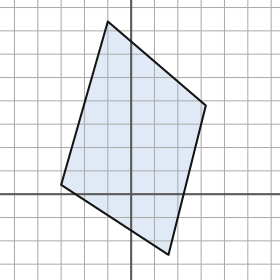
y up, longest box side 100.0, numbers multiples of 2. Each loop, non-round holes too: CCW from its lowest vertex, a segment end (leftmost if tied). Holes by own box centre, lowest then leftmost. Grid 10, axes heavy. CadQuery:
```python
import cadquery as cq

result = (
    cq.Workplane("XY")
    .moveTo(16.0, -26.0)
    .lineTo(32.0, 38.0)
    .lineTo(-10.0, 74.0)
    .lineTo(-30.0, 4.0)
    .close()
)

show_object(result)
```